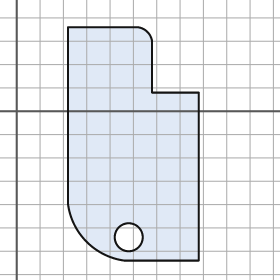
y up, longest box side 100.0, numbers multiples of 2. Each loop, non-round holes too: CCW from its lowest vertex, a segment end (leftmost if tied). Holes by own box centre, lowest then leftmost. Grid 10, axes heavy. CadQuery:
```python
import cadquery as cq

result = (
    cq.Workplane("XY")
    .moveTo(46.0, -64.0)
    .lineTo(78.0, -64.0)
    .lineTo(78.0, 8.0)
    .lineTo(58.0, 8.0)
    .lineTo(58.0, 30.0)
    .threePointArc((56.0, 34.0), (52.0, 36.0))
    .lineTo(22.0, 36.0)
    .lineTo(22.0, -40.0)
    .threePointArc((30.0, -56.0), (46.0, -64.0))
    .close()
    .moveTo(48.0, -54.0)
    .circle(6.0)
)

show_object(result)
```